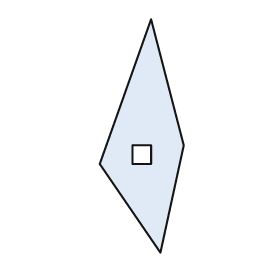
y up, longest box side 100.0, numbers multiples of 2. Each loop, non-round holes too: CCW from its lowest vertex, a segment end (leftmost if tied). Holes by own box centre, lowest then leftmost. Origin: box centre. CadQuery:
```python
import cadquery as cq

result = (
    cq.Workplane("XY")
    .moveTo(8.0, -50.0)
    .lineTo(18.0, -4.0)
    .lineTo(4.0, 50.0)
    .lineTo(-18.0, -12.0)
    .close()
    .moveTo(-4.0, -12.0)
    .lineTo(4.0, -12.0)
    .lineTo(4.0, -4.0)
    .lineTo(-4.0, -4.0)
    .close()
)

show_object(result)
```